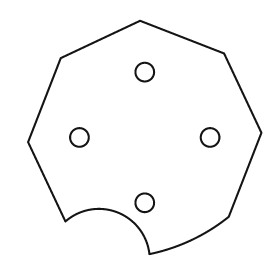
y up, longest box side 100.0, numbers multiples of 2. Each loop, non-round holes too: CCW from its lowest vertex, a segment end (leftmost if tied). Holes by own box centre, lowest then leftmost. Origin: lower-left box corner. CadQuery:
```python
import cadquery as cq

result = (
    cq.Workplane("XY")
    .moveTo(52.0, 0.0)
    .threePointArc((70.0, 6.0), (86.0, 16.0))
    .lineTo(100.0, 52.0)
    .lineTo(84.0, 86.0)
    .lineTo(48.0, 100.0)
    .lineTo(14.0, 84.0)
    .lineTo(0.0, 48.0)
    .lineTo(16.0, 14.0)
    .threePointArc((38.0, 18.0), (52.0, 0.0))
    .close()
    .moveTo(50.0, 22.0)
    .circle(4.0)
    .moveTo(22.0, 50.0)
    .circle(4.0)
    .moveTo(78.0, 50.0)
    .circle(4.0)
    .moveTo(50.0, 78.0)
    .circle(4.0)
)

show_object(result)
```